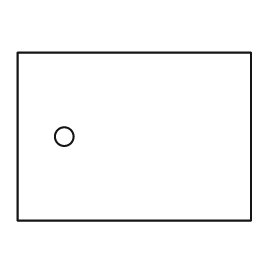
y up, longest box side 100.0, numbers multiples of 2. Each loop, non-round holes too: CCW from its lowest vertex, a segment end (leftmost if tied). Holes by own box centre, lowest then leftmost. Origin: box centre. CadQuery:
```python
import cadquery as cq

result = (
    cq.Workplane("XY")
    .moveTo(-50.0, -36.0)
    .lineTo(50.0, -36.0)
    .lineTo(50.0, 36.0)
    .lineTo(-50.0, 36.0)
    .close()
    .moveTo(-30.0, 0.0)
    .circle(4.0)
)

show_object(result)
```